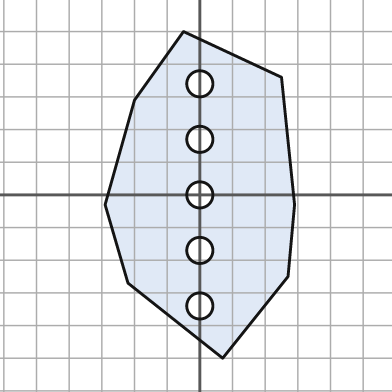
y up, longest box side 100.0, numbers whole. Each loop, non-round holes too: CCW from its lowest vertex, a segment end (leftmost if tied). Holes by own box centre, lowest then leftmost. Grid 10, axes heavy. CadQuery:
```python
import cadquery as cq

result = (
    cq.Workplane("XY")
    .moveTo(7.0, -50.0)
    .lineTo(27.0, -25.0)
    .lineTo(29.0, -3.0)
    .lineTo(25.0, 36.0)
    .lineTo(-5.0, 50.0)
    .lineTo(-20.0, 29.0)
    .lineTo(-29.0, -3.0)
    .lineTo(-22.0, -27.0)
    .close()
    .moveTo(0.0, -34.0)
    .circle(4.0)
    .moveTo(0.0, -17.0)
    .circle(4.0)
    .moveTo(0.0, 0.0)
    .circle(4.0)
    .moveTo(0.0, 17.0)
    .circle(4.0)
    .moveTo(0.0, 34.0)
    .circle(4.0)
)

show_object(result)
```